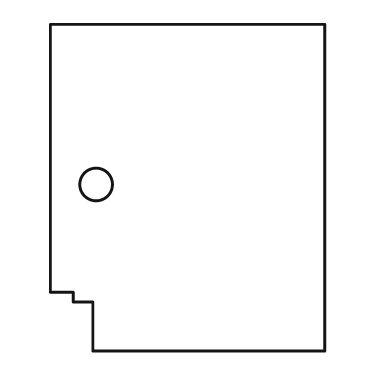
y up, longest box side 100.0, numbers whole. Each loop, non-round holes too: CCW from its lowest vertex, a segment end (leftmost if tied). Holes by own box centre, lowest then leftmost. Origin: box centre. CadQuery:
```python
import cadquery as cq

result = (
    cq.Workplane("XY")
    .moveTo(-29.0, -50.0)
    .lineTo(42.0, -50.0)
    .lineTo(42.0, 50.0)
    .lineTo(-42.0, 50.0)
    .lineTo(-42.0, -32.0)
    .lineTo(-35.0, -32.0)
    .lineTo(-35.0, -35.0)
    .lineTo(-29.0, -35.0)
    .close()
    .moveTo(-28.0, 1.0)
    .circle(5.0)
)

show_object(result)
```